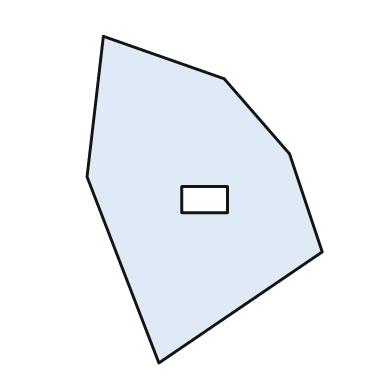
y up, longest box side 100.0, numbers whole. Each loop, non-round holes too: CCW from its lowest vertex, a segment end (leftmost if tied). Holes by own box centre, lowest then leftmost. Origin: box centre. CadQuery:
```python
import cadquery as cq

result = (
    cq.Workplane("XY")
    .moveTo(-14.0, -50.0)
    .lineTo(36.0, -16.0)
    .lineTo(26.0, 14.0)
    .lineTo(6.0, 37.0)
    .lineTo(-31.0, 50.0)
    .lineTo(-36.0, 7.0)
    .close()
    .moveTo(-7.0, -4.0)
    .lineTo(7.0, -4.0)
    .lineTo(7.0, 4.0)
    .lineTo(-7.0, 4.0)
    .close()
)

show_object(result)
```